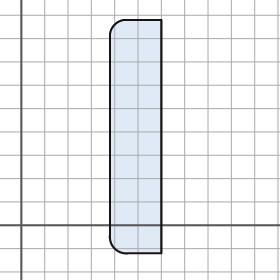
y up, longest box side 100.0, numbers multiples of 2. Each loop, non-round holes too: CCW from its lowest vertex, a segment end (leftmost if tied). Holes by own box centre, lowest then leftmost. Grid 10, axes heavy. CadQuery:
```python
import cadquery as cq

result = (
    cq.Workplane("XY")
    .moveTo(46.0, -12.0)
    .lineTo(60.0, -12.0)
    .lineTo(60.0, 88.0)
    .lineTo(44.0, 88.0)
    .threePointArc((40.0, 86.0), (38.0, 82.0))
    .lineTo(38.0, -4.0)
    .threePointArc((40.0, -10.0), (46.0, -12.0))
    .close()
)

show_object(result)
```